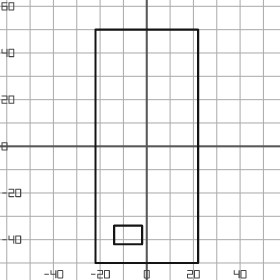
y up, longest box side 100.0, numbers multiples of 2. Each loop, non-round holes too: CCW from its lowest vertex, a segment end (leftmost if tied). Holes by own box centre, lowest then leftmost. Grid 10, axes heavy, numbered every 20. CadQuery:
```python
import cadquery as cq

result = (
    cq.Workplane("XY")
    .moveTo(-22.0, -50.0)
    .lineTo(22.0, -50.0)
    .lineTo(22.0, 50.0)
    .lineTo(-22.0, 50.0)
    .close()
    .moveTo(-14.0, -42.0)
    .lineTo(-2.0, -42.0)
    .lineTo(-2.0, -34.0)
    .lineTo(-14.0, -34.0)
    .close()
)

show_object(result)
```